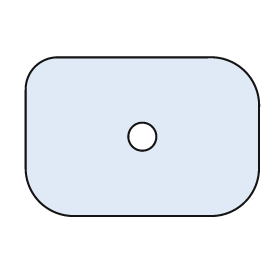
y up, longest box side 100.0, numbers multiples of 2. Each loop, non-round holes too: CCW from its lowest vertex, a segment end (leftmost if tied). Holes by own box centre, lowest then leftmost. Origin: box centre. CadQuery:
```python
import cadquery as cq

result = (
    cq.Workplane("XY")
    .moveTo(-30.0, -34.0)
    .lineTo(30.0, -34.0)
    .threePointArc((44.0, -28.0), (50.0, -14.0))
    .lineTo(50.0, 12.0)
    .threePointArc((44.0, 28.0), (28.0, 34.0))
    .lineTo(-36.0, 34.0)
    .threePointArc((-46.0, 30.0), (-50.0, 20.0))
    .lineTo(-50.0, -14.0)
    .threePointArc((-44.0, -28.0), (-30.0, -34.0))
    .close()
    .moveTo(0.0, 0.0)
    .circle(6.0)
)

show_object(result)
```